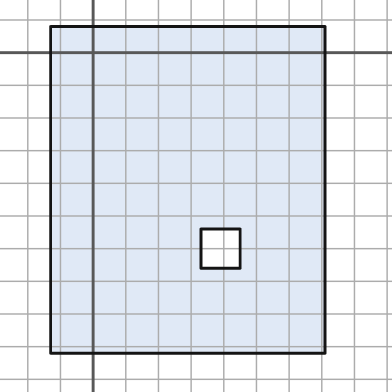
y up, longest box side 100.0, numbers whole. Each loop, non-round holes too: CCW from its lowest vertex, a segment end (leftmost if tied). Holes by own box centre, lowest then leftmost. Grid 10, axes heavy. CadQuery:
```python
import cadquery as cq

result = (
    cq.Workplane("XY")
    .moveTo(-13.0, -92.0)
    .lineTo(71.0, -92.0)
    .lineTo(71.0, 8.0)
    .lineTo(-13.0, 8.0)
    .close()
    .moveTo(33.0, -66.0)
    .lineTo(45.0, -66.0)
    .lineTo(45.0, -54.0)
    .lineTo(33.0, -54.0)
    .close()
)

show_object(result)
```